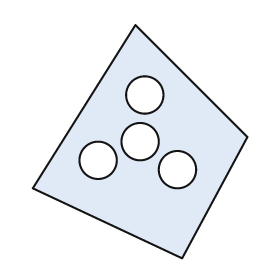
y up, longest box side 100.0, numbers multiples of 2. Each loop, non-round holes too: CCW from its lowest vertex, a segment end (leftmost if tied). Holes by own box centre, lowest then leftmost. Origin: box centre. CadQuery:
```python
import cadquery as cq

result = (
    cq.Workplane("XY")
    .moveTo(18.0, -50.0)
    .lineTo(46.0, 2.0)
    .lineTo(-2.0, 50.0)
    .lineTo(-46.0, -20.0)
    .close()
    .moveTo(16.0, -12.0)
    .circle(8.0)
    .moveTo(-18.0, -8.0)
    .circle(8.0)
    .moveTo(0.0, 0.0)
    .circle(8.0)
    .moveTo(2.0, 20.0)
    .circle(8.0)
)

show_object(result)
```